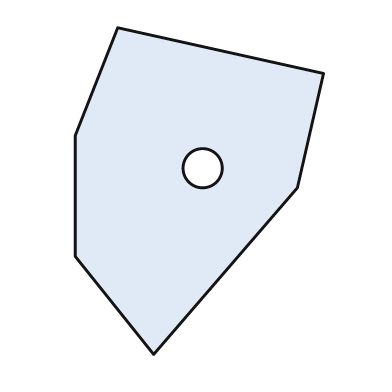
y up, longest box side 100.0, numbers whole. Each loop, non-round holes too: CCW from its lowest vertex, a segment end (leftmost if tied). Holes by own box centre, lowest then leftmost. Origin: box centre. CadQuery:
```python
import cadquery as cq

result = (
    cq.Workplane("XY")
    .moveTo(-14.0, -50.0)
    .lineTo(30.0, 1.0)
    .lineTo(38.0, 36.0)
    .lineTo(-25.0, 50.0)
    .lineTo(-38.0, 17.0)
    .lineTo(-38.0, -20.0)
    .close()
    .moveTo(1.0, 7.0)
    .circle(6.0)
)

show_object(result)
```